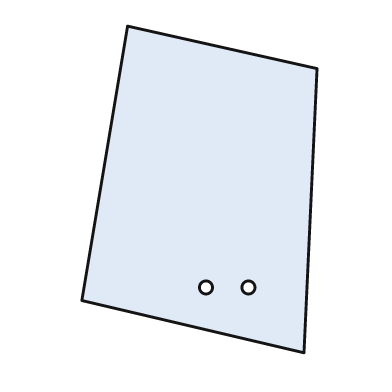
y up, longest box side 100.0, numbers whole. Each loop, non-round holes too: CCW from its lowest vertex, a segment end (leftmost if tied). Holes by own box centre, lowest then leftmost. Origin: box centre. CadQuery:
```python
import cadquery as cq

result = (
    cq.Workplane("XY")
    .moveTo(32.0, -50.0)
    .lineTo(36.0, 37.0)
    .lineTo(-22.0, 50.0)
    .lineTo(-36.0, -34.0)
    .close()
    .moveTo(2.0, -30.0)
    .circle(2.0)
    .moveTo(15.0, -30.0)
    .circle(2.0)
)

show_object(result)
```